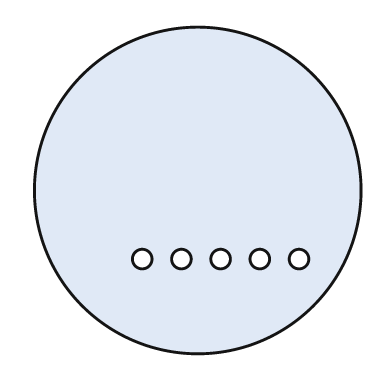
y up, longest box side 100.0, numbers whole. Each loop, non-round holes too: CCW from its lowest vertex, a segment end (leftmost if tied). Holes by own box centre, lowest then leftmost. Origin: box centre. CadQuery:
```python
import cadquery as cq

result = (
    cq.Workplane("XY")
    .moveTo(0.0, 0.0)
    .circle(50.0)
    .moveTo(-17.0, -21.0)
    .circle(3.0)
    .moveTo(-5.0, -21.0)
    .circle(3.0)
    .moveTo(7.0, -21.0)
    .circle(3.0)
    .moveTo(19.0, -21.0)
    .circle(3.0)
    .moveTo(31.0, -21.0)
    .circle(3.0)
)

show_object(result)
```